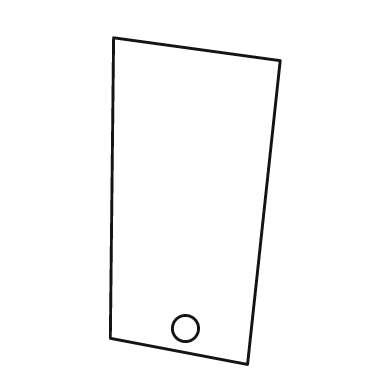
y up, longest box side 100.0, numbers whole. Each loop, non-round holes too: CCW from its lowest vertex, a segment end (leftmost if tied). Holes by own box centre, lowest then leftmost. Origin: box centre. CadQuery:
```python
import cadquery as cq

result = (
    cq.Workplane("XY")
    .moveTo(16.0, -50.0)
    .lineTo(26.0, 43.0)
    .lineTo(-25.0, 50.0)
    .lineTo(-26.0, -42.0)
    .close()
    .moveTo(-3.0, -39.0)
    .circle(4.0)
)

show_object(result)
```